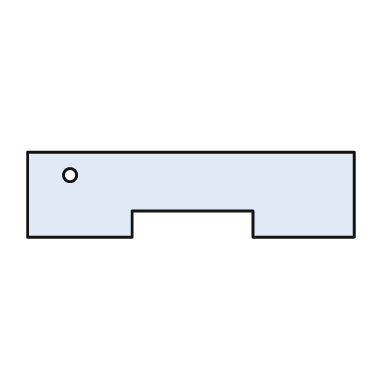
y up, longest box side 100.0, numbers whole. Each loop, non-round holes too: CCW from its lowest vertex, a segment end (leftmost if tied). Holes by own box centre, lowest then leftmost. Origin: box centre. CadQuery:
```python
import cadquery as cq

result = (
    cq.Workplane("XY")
    .moveTo(-50.0, -13.0)
    .lineTo(-18.0, -13.0)
    .lineTo(-18.0, -5.0)
    .lineTo(19.0, -5.0)
    .lineTo(19.0, -13.0)
    .lineTo(50.0, -13.0)
    .lineTo(50.0, 13.0)
    .lineTo(-50.0, 13.0)
    .close()
    .moveTo(-37.0, 6.0)
    .circle(2.0)
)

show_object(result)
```